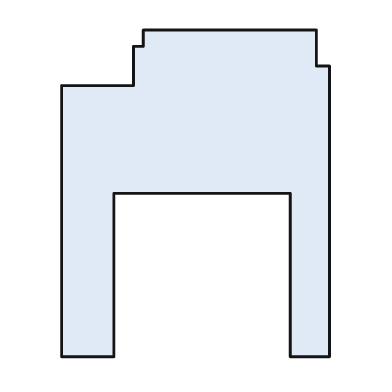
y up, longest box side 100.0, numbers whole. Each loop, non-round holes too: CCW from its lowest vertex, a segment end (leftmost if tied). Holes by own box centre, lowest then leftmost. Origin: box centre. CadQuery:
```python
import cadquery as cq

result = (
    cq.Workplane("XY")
    .moveTo(-41.0, -50.0)
    .lineTo(-25.0, -50.0)
    .lineTo(-25.0, 0.0)
    .lineTo(29.0, 0.0)
    .lineTo(29.0, -50.0)
    .lineTo(41.0, -50.0)
    .lineTo(41.0, 39.0)
    .lineTo(37.0, 39.0)
    .lineTo(37.0, 50.0)
    .lineTo(-16.0, 50.0)
    .lineTo(-16.0, 45.0)
    .lineTo(-19.0, 45.0)
    .lineTo(-19.0, 33.0)
    .lineTo(-41.0, 33.0)
    .close()
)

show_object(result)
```